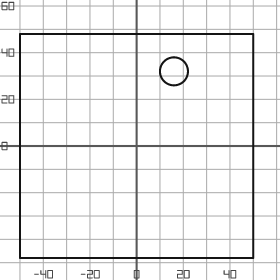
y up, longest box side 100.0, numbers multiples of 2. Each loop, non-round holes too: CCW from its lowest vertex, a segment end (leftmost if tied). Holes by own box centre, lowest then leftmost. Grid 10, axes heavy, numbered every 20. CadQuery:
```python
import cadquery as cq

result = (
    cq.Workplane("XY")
    .moveTo(-50.0, -48.0)
    .lineTo(50.0, -48.0)
    .lineTo(50.0, 48.0)
    .lineTo(-50.0, 48.0)
    .close()
    .moveTo(16.0, 32.0)
    .circle(6.0)
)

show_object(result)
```